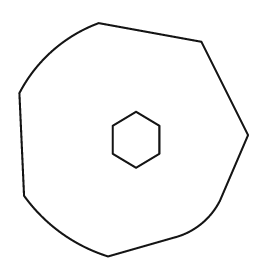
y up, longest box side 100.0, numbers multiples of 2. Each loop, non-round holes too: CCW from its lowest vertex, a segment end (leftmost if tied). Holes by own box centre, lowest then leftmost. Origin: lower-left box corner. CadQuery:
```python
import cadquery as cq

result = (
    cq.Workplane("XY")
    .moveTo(38.0, 0.0)
    .lineTo(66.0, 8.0)
    .threePointArc((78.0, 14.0), (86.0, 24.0))
    .lineTo(98.0, 52.0)
    .lineTo(78.0, 92.0)
    .lineTo(34.0, 100.0)
    .threePointArc((14.0, 88.0), (0.0, 70.0))
    .lineTo(2.0, 26.0)
    .threePointArc((18.0, 10.0), (38.0, 0.0))
    .close()
    .moveTo(50.0, 38.0)
    .lineTo(60.0, 44.0)
    .lineTo(60.0, 56.0)
    .lineTo(50.0, 62.0)
    .lineTo(40.0, 56.0)
    .lineTo(40.0, 44.0)
    .close()
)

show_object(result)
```